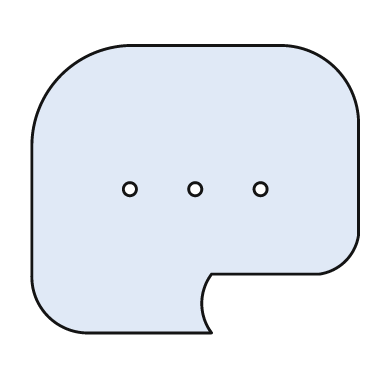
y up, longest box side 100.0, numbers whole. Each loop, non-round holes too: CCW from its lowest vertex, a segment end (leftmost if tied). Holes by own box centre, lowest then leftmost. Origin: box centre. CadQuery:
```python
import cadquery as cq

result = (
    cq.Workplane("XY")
    .moveTo(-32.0, -44.0)
    .lineTo(5.0, -44.0)
    .threePointArc((2.0, -35.0), (5.0, -26.0))
    .lineTo(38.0, -26.0)
    .threePointArc((46.0, -22.0), (50.0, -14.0))
    .lineTo(50.0, 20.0)
    .threePointArc((43.0, 37.0), (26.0, 44.0))
    .lineTo(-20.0, 44.0)
    .threePointArc((-41.0, 35.0), (-50.0, 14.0))
    .lineTo(-50.0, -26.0)
    .threePointArc((-45.0, -39.0), (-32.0, -44.0))
    .close()
    .moveTo(-20.0, 0.0)
    .circle(2.0)
    .moveTo(0.0, 0.0)
    .circle(2.0)
    .moveTo(20.0, 0.0)
    .circle(2.0)
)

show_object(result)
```